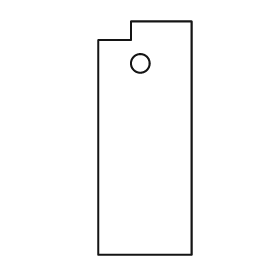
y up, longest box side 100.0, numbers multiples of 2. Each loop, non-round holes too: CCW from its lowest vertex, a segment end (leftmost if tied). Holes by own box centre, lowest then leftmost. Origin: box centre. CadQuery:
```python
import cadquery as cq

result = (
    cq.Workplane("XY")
    .moveTo(-20.0, -50.0)
    .lineTo(20.0, -50.0)
    .lineTo(20.0, 50.0)
    .lineTo(-6.0, 50.0)
    .lineTo(-6.0, 42.0)
    .lineTo(-20.0, 42.0)
    .close()
    .moveTo(-2.0, 32.0)
    .circle(4.0)
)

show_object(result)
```